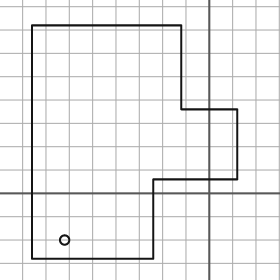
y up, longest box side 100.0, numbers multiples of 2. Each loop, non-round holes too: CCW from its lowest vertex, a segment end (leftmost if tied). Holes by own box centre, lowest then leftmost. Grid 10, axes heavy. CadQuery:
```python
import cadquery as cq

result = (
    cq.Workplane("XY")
    .moveTo(-76.0, -28.0)
    .lineTo(-24.0, -28.0)
    .lineTo(-24.0, 6.0)
    .lineTo(12.0, 6.0)
    .lineTo(12.0, 36.0)
    .lineTo(-12.0, 36.0)
    .lineTo(-12.0, 72.0)
    .lineTo(-76.0, 72.0)
    .close()
    .moveTo(-62.0, -20.0)
    .circle(2.0)
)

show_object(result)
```